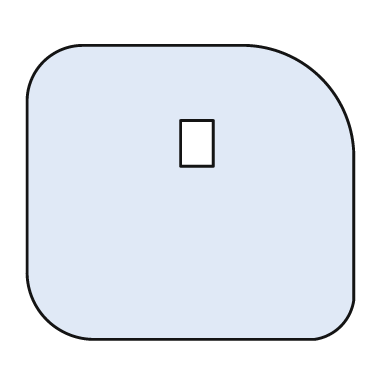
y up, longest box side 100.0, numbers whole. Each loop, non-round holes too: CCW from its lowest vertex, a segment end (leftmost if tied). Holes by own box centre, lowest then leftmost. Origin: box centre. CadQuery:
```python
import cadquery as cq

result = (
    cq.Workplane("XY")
    .moveTo(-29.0, -45.0)
    .lineTo(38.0, -45.0)
    .threePointArc((46.0, -41.0), (50.0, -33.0))
    .lineTo(50.0, 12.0)
    .threePointArc((40.0, 35.0), (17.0, 45.0))
    .lineTo(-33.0, 45.0)
    .threePointArc((-45.0, 40.0), (-50.0, 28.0))
    .lineTo(-50.0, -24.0)
    .threePointArc((-44.0, -39.0), (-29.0, -45.0))
    .close()
    .moveTo(-3.0, 8.0)
    .lineTo(7.0, 8.0)
    .lineTo(7.0, 22.0)
    .lineTo(-3.0, 22.0)
    .close()
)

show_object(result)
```